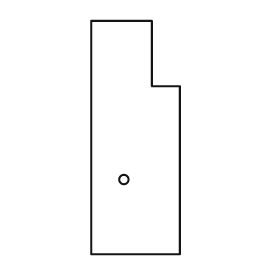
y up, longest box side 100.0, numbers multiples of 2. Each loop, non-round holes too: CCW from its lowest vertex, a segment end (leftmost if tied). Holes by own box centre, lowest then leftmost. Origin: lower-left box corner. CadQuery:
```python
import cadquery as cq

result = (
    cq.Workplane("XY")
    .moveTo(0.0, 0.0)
    .lineTo(38.0, 0.0)
    .lineTo(38.0, 72.0)
    .lineTo(26.0, 72.0)
    .lineTo(26.0, 100.0)
    .lineTo(0.0, 100.0)
    .close()
    .moveTo(14.0, 32.0)
    .circle(2.0)
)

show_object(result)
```